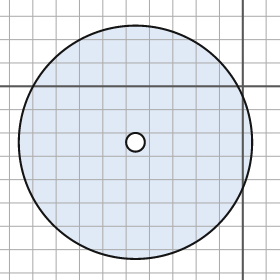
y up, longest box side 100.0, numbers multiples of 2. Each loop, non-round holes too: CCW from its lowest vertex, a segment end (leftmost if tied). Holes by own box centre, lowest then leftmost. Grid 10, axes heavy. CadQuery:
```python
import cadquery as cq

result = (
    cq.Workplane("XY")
    .moveTo(-46.0, -24.0)
    .circle(50.0)
    .moveTo(-46.0, -24.0)
    .circle(4.0)
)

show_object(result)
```